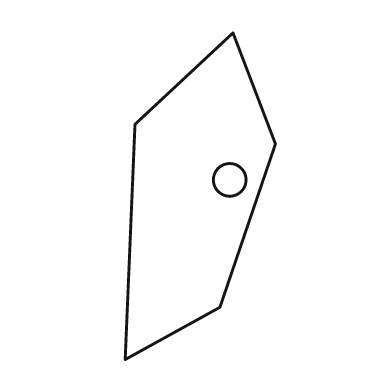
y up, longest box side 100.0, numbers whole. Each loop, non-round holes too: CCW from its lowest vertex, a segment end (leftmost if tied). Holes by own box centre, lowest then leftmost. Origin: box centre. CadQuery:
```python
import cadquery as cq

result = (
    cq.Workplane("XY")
    .moveTo(-23.0, -50.0)
    .lineTo(6.0, -34.0)
    .lineTo(23.0, 16.0)
    .lineTo(10.0, 50.0)
    .lineTo(-20.0, 22.0)
    .close()
    .moveTo(9.0, 5.0)
    .circle(5.0)
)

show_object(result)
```